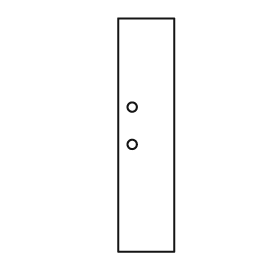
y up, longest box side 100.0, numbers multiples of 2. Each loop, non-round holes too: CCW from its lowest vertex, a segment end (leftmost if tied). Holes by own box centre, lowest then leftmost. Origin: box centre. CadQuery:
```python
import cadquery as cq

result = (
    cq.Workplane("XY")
    .moveTo(-12.0, -50.0)
    .lineTo(12.0, -50.0)
    .lineTo(12.0, 50.0)
    .lineTo(-12.0, 50.0)
    .close()
    .moveTo(-6.0, -4.0)
    .circle(2.0)
    .moveTo(-6.0, 12.0)
    .circle(2.0)
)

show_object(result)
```